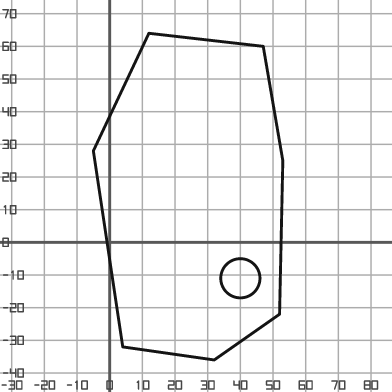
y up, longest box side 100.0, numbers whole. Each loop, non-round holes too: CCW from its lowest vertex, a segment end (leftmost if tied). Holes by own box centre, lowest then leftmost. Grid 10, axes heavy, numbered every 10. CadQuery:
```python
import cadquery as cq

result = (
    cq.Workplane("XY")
    .moveTo(32.0, -36.0)
    .lineTo(52.0, -22.0)
    .lineTo(53.0, 25.0)
    .lineTo(47.0, 60.0)
    .lineTo(12.0, 64.0)
    .lineTo(-5.0, 28.0)
    .lineTo(4.0, -32.0)
    .close()
    .moveTo(40.0, -11.0)
    .circle(6.0)
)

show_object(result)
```